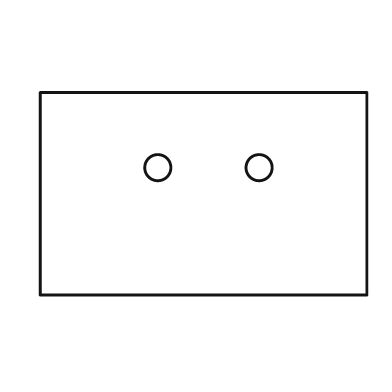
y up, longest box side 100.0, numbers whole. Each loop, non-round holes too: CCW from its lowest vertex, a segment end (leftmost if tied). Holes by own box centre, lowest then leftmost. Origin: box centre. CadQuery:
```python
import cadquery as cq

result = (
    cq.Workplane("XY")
    .moveTo(-50.0, -31.0)
    .lineTo(50.0, -31.0)
    .lineTo(50.0, 31.0)
    .lineTo(-50.0, 31.0)
    .close()
    .moveTo(-14.0, 8.0)
    .circle(4.0)
    .moveTo(17.0, 8.0)
    .circle(4.0)
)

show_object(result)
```